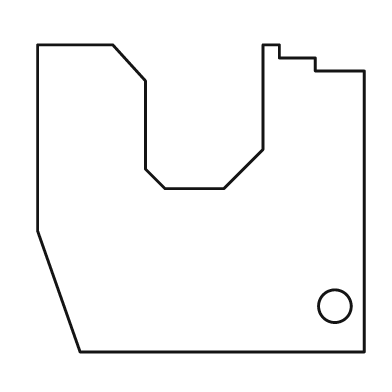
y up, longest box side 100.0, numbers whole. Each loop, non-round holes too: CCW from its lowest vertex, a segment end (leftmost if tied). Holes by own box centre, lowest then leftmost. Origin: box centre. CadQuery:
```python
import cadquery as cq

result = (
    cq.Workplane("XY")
    .moveTo(-37.0, -47.0)
    .lineTo(50.0, -47.0)
    .lineTo(50.0, 39.0)
    .lineTo(35.0, 39.0)
    .lineTo(35.0, 43.0)
    .lineTo(24.0, 43.0)
    .lineTo(24.0, 47.0)
    .lineTo(19.0, 47.0)
    .lineTo(19.0, 15.0)
    .lineTo(7.0, 3.0)
    .lineTo(-11.0, 3.0)
    .lineTo(-17.0, 9.0)
    .lineTo(-17.0, 36.0)
    .lineTo(-27.0, 47.0)
    .lineTo(-50.0, 47.0)
    .lineTo(-50.0, -10.0)
    .close()
    .moveTo(41.0, -33.0)
    .circle(5.0)
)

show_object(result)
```